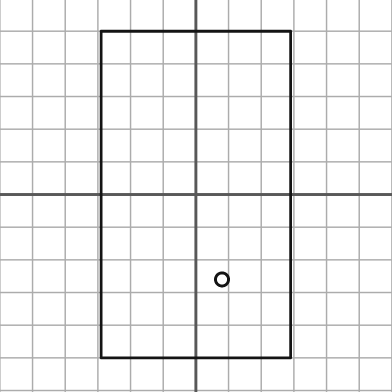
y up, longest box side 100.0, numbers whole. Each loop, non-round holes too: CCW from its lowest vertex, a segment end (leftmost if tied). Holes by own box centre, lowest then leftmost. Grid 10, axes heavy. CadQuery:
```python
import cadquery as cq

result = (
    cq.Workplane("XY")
    .moveTo(-29.0, -50.0)
    .lineTo(29.0, -50.0)
    .lineTo(29.0, 50.0)
    .lineTo(-29.0, 50.0)
    .close()
    .moveTo(8.0, -26.0)
    .circle(2.0)
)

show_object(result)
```